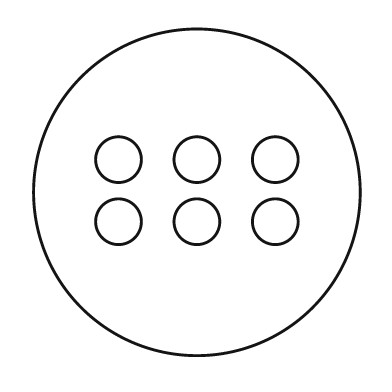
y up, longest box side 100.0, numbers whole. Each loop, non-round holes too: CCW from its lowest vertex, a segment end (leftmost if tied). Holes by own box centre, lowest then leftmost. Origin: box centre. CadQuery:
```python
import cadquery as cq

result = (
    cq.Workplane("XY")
    .moveTo(0.0, 0.0)
    .circle(50.0)
    .moveTo(-24.0, -9.0)
    .circle(7.0)
    .moveTo(0.0, -9.0)
    .circle(7.0)
    .moveTo(24.0, -9.0)
    .circle(7.0)
    .moveTo(-24.0, 10.0)
    .circle(7.0)
    .moveTo(0.0, 10.0)
    .circle(7.0)
    .moveTo(24.0, 10.0)
    .circle(7.0)
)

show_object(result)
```